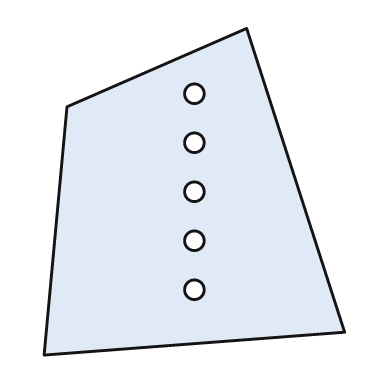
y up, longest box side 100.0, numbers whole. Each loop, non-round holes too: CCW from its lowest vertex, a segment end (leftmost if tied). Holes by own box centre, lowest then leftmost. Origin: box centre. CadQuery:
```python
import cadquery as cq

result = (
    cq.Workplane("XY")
    .moveTo(-46.0, -50.0)
    .lineTo(46.0, -43.0)
    .lineTo(16.0, 50.0)
    .lineTo(-39.0, 26.0)
    .close()
    .moveTo(0.0, -30.0)
    .circle(3.0)
    .moveTo(0.0, -15.0)
    .circle(3.0)
    .moveTo(0.0, 0.0)
    .circle(3.0)
    .moveTo(0.0, 15.0)
    .circle(3.0)
    .moveTo(0.0, 30.0)
    .circle(3.0)
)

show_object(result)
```